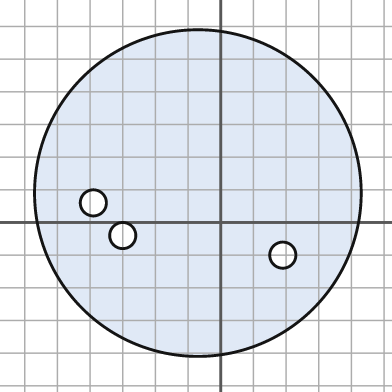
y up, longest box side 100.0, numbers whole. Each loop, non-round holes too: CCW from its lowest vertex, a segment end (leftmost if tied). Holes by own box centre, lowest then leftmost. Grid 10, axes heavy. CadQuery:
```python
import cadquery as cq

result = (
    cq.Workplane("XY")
    .moveTo(-7.0, 9.0)
    .circle(50.0)
    .moveTo(19.0, -10.0)
    .circle(4.0)
    .moveTo(-30.0, -4.0)
    .circle(4.0)
    .moveTo(-39.0, 6.0)
    .circle(4.0)
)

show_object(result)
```